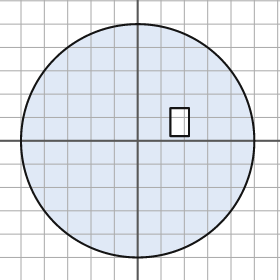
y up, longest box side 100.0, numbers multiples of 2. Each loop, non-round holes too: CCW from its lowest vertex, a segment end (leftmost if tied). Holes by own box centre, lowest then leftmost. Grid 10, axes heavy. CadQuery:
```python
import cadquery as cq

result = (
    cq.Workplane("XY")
    .moveTo(0.0, 0.0)
    .circle(50.0)
    .moveTo(14.0, 2.0)
    .lineTo(22.0, 2.0)
    .lineTo(22.0, 14.0)
    .lineTo(14.0, 14.0)
    .close()
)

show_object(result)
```